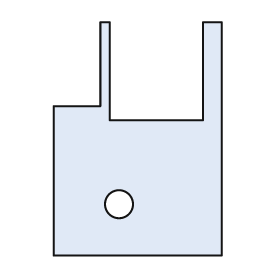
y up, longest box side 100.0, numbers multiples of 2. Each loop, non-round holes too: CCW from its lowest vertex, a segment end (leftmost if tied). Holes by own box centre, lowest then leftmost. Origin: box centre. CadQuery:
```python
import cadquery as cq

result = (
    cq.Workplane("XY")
    .moveTo(-36.0, -50.0)
    .lineTo(36.0, -50.0)
    .lineTo(36.0, 50.0)
    .lineTo(28.0, 50.0)
    .lineTo(28.0, 8.0)
    .lineTo(-12.0, 8.0)
    .lineTo(-12.0, 50.0)
    .lineTo(-16.0, 50.0)
    .lineTo(-16.0, 14.0)
    .lineTo(-36.0, 14.0)
    .close()
    .moveTo(-8.0, -28.0)
    .circle(6.0)
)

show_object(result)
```